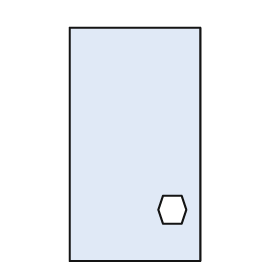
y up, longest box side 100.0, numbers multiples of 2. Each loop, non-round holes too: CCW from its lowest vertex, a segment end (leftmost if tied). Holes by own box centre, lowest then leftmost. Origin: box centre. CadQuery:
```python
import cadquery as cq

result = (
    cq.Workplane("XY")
    .moveTo(-28.0, -50.0)
    .lineTo(28.0, -50.0)
    .lineTo(28.0, 50.0)
    .lineTo(-28.0, 50.0)
    .close()
    .moveTo(12.0, -34.0)
    .lineTo(20.0, -34.0)
    .lineTo(22.0, -28.0)
    .lineTo(20.0, -22.0)
    .lineTo(12.0, -22.0)
    .lineTo(10.0, -28.0)
    .close()
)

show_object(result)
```